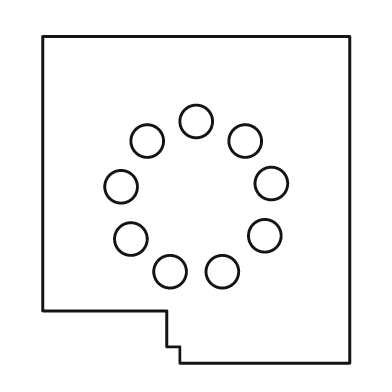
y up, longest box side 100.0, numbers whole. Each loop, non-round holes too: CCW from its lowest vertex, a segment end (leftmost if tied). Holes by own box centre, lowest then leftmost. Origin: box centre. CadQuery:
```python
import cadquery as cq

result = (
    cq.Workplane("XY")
    .moveTo(-5.0, -50.0)
    .lineTo(47.0, -50.0)
    .lineTo(47.0, 50.0)
    .lineTo(-47.0, 50.0)
    .lineTo(-47.0, -34.0)
    .lineTo(-9.0, -34.0)
    .lineTo(-9.0, -45.0)
    .lineTo(-5.0, -45.0)
    .close()
    .moveTo(-8.0, -22.0)
    .circle(5.0)
    .moveTo(8.0, -22.0)
    .circle(5.0)
    .moveTo(-20.0, -12.0)
    .circle(5.0)
    .moveTo(21.0, -11.0)
    .circle(5.0)
    .moveTo(-23.0, 4.0)
    .circle(5.0)
    .moveTo(23.0, 5.0)
    .circle(5.0)
    .moveTo(-15.0, 18.0)
    .circle(5.0)
    .moveTo(15.0, 18.0)
    .circle(5.0)
    .moveTo(0.0, 24.0)
    .circle(5.0)
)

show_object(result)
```